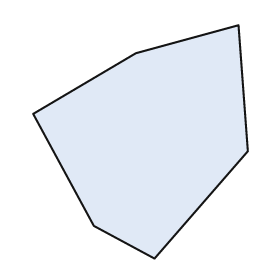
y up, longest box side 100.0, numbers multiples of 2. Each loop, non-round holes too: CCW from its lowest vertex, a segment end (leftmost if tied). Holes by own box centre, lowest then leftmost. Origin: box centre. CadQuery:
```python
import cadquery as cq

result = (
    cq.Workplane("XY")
    .moveTo(6.0, -50.0)
    .lineTo(46.0, -4.0)
    .lineTo(42.0, 50.0)
    .lineTo(-2.0, 38.0)
    .lineTo(-46.0, 12.0)
    .lineTo(-20.0, -36.0)
    .close()
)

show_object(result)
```